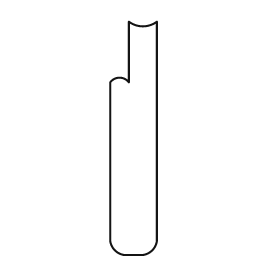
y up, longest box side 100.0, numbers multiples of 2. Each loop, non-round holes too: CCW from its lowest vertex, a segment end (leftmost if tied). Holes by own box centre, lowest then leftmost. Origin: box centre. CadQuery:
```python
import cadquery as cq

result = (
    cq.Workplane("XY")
    .moveTo(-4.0, -50.0)
    .lineTo(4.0, -50.0)
    .threePointArc((8.0, -48.0), (10.0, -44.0))
    .lineTo(10.0, 50.0)
    .threePointArc((4.0, 48.0), (-2.0, 50.0))
    .lineTo(-2.0, 24.0)
    .threePointArc((-6.0, 26.0), (-10.0, 24.0))
    .lineTo(-10.0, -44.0)
    .threePointArc((-8.0, -48.0), (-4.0, -50.0))
    .close()
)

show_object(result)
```